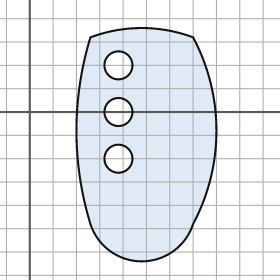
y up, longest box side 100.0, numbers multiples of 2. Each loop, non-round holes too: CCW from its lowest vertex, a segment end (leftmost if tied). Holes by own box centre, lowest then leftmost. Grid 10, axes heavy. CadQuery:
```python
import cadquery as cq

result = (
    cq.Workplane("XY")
    .moveTo(26.0, -48.0)
    .threePointArc((48.0, -64.0), (70.0, -48.0))
    .threePointArc((80.0, -8.0), (70.0, 32.0))
    .threePointArc((48.0, 36.0), (26.0, 32.0))
    .threePointArc((20.0, -8.0), (26.0, -48.0))
    .close()
    .moveTo(38.0, -20.0)
    .circle(6.0)
    .moveTo(38.0, 0.0)
    .circle(6.0)
    .moveTo(38.0, 20.0)
    .circle(6.0)
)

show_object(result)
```